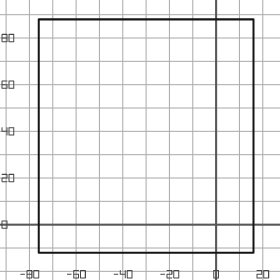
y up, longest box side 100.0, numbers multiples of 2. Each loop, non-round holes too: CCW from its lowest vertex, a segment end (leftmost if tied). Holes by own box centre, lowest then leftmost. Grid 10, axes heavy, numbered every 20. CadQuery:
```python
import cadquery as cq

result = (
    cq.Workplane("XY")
    .moveTo(-76.0, -12.0)
    .lineTo(16.0, -12.0)
    .lineTo(16.0, 88.0)
    .lineTo(-76.0, 88.0)
    .close()
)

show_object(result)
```